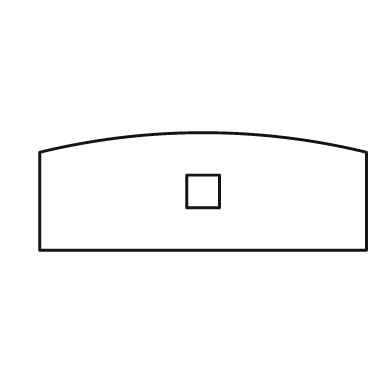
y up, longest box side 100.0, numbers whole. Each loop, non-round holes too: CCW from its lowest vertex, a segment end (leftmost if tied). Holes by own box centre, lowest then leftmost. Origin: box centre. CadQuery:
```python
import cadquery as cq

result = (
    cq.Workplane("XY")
    .moveTo(-50.0, -18.0)
    .lineTo(50.0, -18.0)
    .lineTo(50.0, 12.0)
    .threePointArc((0.0, 18.0), (-50.0, 12.0))
    .close()
    .moveTo(-5.0, -5.0)
    .lineTo(5.0, -5.0)
    .lineTo(5.0, 5.0)
    .lineTo(-5.0, 5.0)
    .close()
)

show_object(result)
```